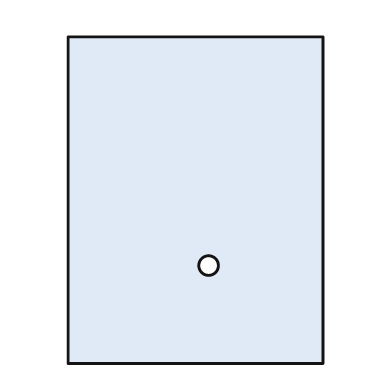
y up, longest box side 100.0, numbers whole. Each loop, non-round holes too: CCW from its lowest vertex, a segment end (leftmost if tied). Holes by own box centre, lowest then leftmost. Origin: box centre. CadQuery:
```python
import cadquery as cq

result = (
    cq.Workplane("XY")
    .moveTo(-39.0, -50.0)
    .lineTo(39.0, -50.0)
    .lineTo(39.0, 50.0)
    .lineTo(-39.0, 50.0)
    .close()
    .moveTo(4.0, -20.0)
    .circle(3.0)
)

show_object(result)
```